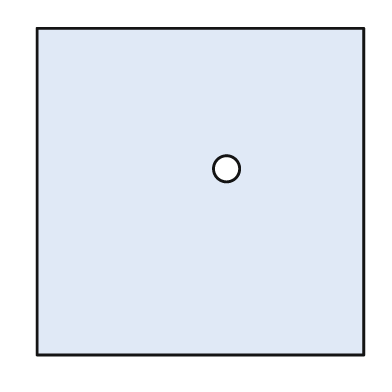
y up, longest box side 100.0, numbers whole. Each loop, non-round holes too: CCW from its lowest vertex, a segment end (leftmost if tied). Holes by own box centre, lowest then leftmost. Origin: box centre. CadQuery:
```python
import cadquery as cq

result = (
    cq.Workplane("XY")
    .moveTo(-50.0, -50.0)
    .lineTo(50.0, -50.0)
    .lineTo(50.0, 50.0)
    .lineTo(-50.0, 50.0)
    .close()
    .moveTo(8.0, 7.0)
    .circle(4.0)
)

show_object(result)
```